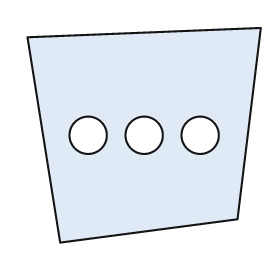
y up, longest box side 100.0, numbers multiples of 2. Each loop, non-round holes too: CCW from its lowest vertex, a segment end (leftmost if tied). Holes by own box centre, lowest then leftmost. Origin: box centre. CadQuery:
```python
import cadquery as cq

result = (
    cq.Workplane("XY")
    .moveTo(-36.0, -46.0)
    .lineTo(40.0, -36.0)
    .lineTo(50.0, 46.0)
    .lineTo(-50.0, 42.0)
    .close()
    .moveTo(-24.0, 0.0)
    .circle(8.0)
    .moveTo(0.0, 0.0)
    .circle(8.0)
    .moveTo(24.0, 0.0)
    .circle(8.0)
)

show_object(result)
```